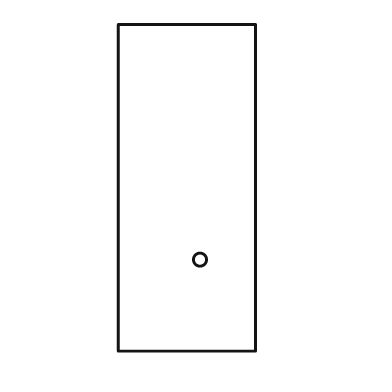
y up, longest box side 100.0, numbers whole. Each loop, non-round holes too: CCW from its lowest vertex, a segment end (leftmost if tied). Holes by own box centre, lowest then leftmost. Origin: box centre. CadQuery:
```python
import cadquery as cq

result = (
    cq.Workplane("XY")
    .moveTo(-21.0, -50.0)
    .lineTo(21.0, -50.0)
    .lineTo(21.0, 50.0)
    .lineTo(-21.0, 50.0)
    .close()
    .moveTo(4.0, -22.0)
    .circle(2.0)
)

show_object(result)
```